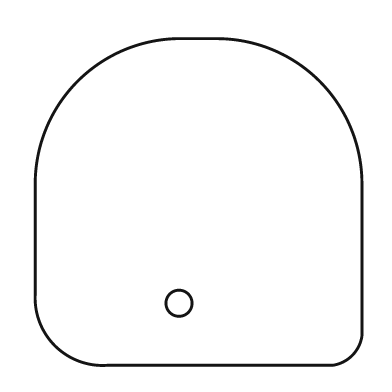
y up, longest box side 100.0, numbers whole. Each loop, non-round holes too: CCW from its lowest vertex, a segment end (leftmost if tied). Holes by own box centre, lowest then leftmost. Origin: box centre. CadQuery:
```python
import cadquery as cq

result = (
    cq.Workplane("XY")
    .moveTo(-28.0, -50.0)
    .lineTo(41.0, -50.0)
    .threePointArc((47.0, -47.0), (50.0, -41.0))
    .lineTo(50.0, 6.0)
    .threePointArc((37.0, 37.0), (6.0, 50.0))
    .lineTo(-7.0, 50.0)
    .threePointArc((-37.0, 37.0), (-50.0, 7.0))
    .lineTo(-50.0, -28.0)
    .threePointArc((-44.0, -44.0), (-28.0, -50.0))
    .close()
    .moveTo(-6.0, -31.0)
    .circle(4.0)
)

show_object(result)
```